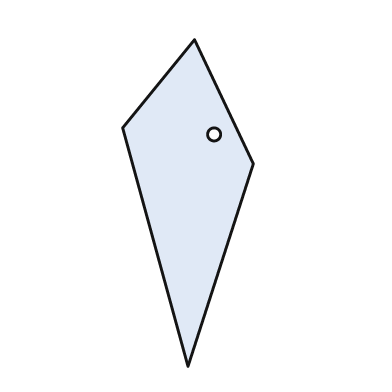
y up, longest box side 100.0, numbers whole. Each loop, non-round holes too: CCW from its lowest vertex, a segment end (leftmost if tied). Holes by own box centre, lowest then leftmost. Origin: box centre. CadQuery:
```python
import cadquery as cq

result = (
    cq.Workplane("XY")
    .moveTo(0.0, -50.0)
    .lineTo(20.0, 12.0)
    .lineTo(2.0, 50.0)
    .lineTo(-20.0, 23.0)
    .close()
    .moveTo(8.0, 21.0)
    .circle(2.0)
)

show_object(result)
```